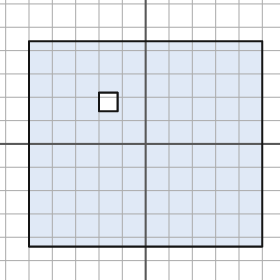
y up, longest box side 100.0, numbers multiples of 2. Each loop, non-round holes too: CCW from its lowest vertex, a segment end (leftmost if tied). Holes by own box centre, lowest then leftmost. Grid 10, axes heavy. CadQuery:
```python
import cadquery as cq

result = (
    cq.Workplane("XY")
    .moveTo(-50.0, -44.0)
    .lineTo(50.0, -44.0)
    .lineTo(50.0, 44.0)
    .lineTo(-50.0, 44.0)
    .close()
    .moveTo(-20.0, 14.0)
    .lineTo(-12.0, 14.0)
    .lineTo(-12.0, 22.0)
    .lineTo(-20.0, 22.0)
    .close()
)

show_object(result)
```